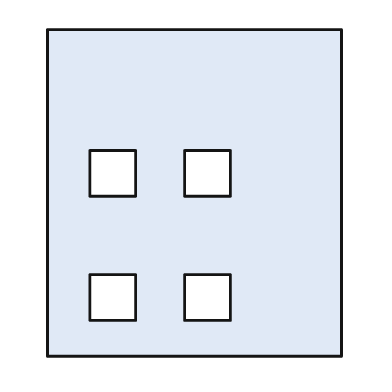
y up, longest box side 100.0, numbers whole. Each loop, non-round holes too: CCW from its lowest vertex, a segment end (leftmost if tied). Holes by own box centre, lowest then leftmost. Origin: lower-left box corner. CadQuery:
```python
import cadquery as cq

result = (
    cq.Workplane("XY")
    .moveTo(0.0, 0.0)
    .lineTo(90.0, 0.0)
    .lineTo(90.0, 100.0)
    .lineTo(0.0, 100.0)
    .close()
    .moveTo(13.0, 11.0)
    .lineTo(27.0, 11.0)
    .lineTo(27.0, 25.0)
    .lineTo(13.0, 25.0)
    .close()
    .moveTo(42.0, 11.0)
    .lineTo(56.0, 11.0)
    .lineTo(56.0, 25.0)
    .lineTo(42.0, 25.0)
    .close()
    .moveTo(13.0, 49.0)
    .lineTo(27.0, 49.0)
    .lineTo(27.0, 63.0)
    .lineTo(13.0, 63.0)
    .close()
    .moveTo(42.0, 49.0)
    .lineTo(56.0, 49.0)
    .lineTo(56.0, 63.0)
    .lineTo(42.0, 63.0)
    .close()
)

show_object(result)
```